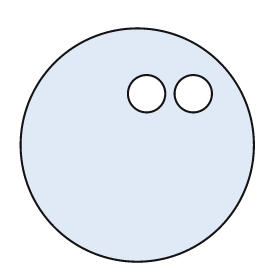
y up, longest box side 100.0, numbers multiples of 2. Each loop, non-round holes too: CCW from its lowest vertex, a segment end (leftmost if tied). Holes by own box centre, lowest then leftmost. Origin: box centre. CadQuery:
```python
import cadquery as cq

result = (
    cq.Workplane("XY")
    .moveTo(0.0, 0.0)
    .circle(50.0)
    .moveTo(4.0, 22.0)
    .circle(8.0)
    .moveTo(24.0, 22.0)
    .circle(8.0)
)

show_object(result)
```